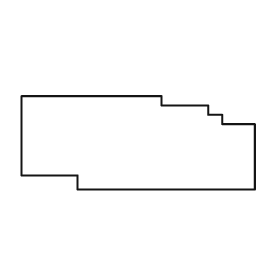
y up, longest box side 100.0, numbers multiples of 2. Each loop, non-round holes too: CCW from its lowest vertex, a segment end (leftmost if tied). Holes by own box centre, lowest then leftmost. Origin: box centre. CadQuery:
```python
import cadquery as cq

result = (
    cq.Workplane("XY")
    .moveTo(-26.0, -20.0)
    .lineTo(50.0, -20.0)
    .lineTo(50.0, 8.0)
    .lineTo(36.0, 8.0)
    .lineTo(36.0, 12.0)
    .lineTo(30.0, 12.0)
    .lineTo(30.0, 16.0)
    .lineTo(10.0, 16.0)
    .lineTo(10.0, 20.0)
    .lineTo(-50.0, 20.0)
    .lineTo(-50.0, -14.0)
    .lineTo(-26.0, -14.0)
    .close()
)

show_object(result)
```